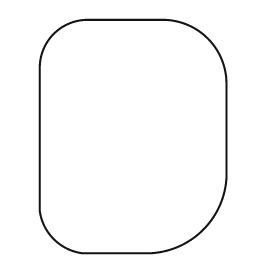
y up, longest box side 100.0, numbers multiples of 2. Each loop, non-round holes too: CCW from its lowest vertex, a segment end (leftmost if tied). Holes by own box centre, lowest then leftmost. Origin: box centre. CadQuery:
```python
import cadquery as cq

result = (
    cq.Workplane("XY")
    .moveTo(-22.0, -50.0)
    .lineTo(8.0, -50.0)
    .threePointArc((30.0, -40.0), (40.0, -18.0))
    .lineTo(40.0, 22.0)
    .threePointArc((32.0, 42.0), (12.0, 50.0))
    .lineTo(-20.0, 50.0)
    .threePointArc((-34.0, 44.0), (-40.0, 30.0))
    .lineTo(-40.0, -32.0)
    .threePointArc((-34.0, -44.0), (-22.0, -50.0))
    .close()
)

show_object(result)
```